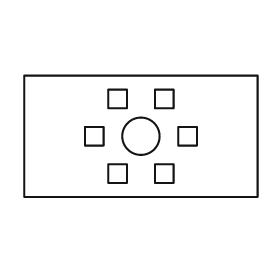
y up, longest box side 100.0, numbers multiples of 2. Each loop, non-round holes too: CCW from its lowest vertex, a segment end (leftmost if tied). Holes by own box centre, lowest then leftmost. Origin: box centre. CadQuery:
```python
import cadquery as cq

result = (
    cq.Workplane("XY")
    .moveTo(-50.0, -26.0)
    .lineTo(50.0, -26.0)
    .lineTo(50.0, 26.0)
    .lineTo(-50.0, 26.0)
    .close()
    .moveTo(-14.0, -20.0)
    .lineTo(-6.0, -20.0)
    .lineTo(-6.0, -12.0)
    .lineTo(-14.0, -12.0)
    .close()
    .moveTo(6.0, -20.0)
    .lineTo(14.0, -20.0)
    .lineTo(14.0, -12.0)
    .lineTo(6.0, -12.0)
    .close()
    .moveTo(-24.0, -4.0)
    .lineTo(-16.0, -4.0)
    .lineTo(-16.0, 4.0)
    .lineTo(-24.0, 4.0)
    .close()
    .moveTo(0.0, 0.0)
    .circle(8.0)
    .moveTo(16.0, -4.0)
    .lineTo(24.0, -4.0)
    .lineTo(24.0, 4.0)
    .lineTo(16.0, 4.0)
    .close()
    .moveTo(-14.0, 12.0)
    .lineTo(-6.0, 12.0)
    .lineTo(-6.0, 20.0)
    .lineTo(-14.0, 20.0)
    .close()
    .moveTo(6.0, 12.0)
    .lineTo(14.0, 12.0)
    .lineTo(14.0, 20.0)
    .lineTo(6.0, 20.0)
    .close()
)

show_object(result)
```